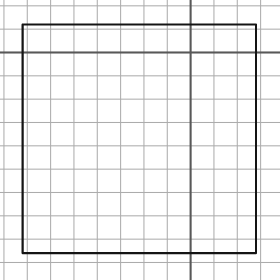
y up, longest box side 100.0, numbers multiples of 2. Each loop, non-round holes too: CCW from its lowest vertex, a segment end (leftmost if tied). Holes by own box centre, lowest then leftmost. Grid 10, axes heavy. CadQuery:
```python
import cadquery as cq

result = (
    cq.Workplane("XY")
    .moveTo(-72.0, -86.0)
    .lineTo(28.0, -86.0)
    .lineTo(28.0, 12.0)
    .lineTo(-72.0, 12.0)
    .close()
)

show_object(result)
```